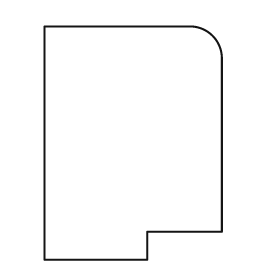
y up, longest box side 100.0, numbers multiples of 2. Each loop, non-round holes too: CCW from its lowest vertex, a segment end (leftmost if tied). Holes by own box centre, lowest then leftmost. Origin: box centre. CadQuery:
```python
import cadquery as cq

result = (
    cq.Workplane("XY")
    .moveTo(-38.0, -50.0)
    .lineTo(6.0, -50.0)
    .lineTo(6.0, -38.0)
    .lineTo(38.0, -38.0)
    .lineTo(38.0, 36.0)
    .threePointArc((34.0, 46.0), (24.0, 50.0))
    .lineTo(-38.0, 50.0)
    .close()
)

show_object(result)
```